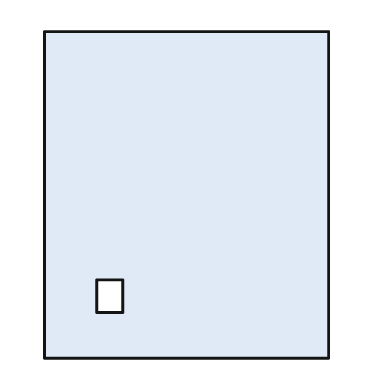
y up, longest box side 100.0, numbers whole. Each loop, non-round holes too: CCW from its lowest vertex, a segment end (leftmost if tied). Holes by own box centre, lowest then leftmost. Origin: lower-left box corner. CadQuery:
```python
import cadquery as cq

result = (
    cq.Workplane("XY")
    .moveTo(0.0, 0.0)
    .lineTo(87.0, 0.0)
    .lineTo(87.0, 100.0)
    .lineTo(0.0, 100.0)
    .close()
    .moveTo(16.0, 14.0)
    .lineTo(24.0, 14.0)
    .lineTo(24.0, 24.0)
    .lineTo(16.0, 24.0)
    .close()
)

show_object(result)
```